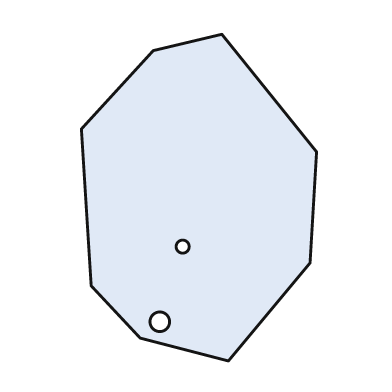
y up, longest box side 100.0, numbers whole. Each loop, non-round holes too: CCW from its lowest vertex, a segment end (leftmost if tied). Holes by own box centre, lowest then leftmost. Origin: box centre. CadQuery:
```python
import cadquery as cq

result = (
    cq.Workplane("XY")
    .moveTo(9.0, -50.0)
    .lineTo(34.0, -20.0)
    .lineTo(36.0, 14.0)
    .lineTo(7.0, 50.0)
    .lineTo(-14.0, 45.0)
    .lineTo(-36.0, 21.0)
    .lineTo(-33.0, -27.0)
    .lineTo(-18.0, -43.0)
    .close()
    .moveTo(-12.0, -38.0)
    .circle(3.0)
    .moveTo(-5.0, -15.0)
    .circle(2.0)
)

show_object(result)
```